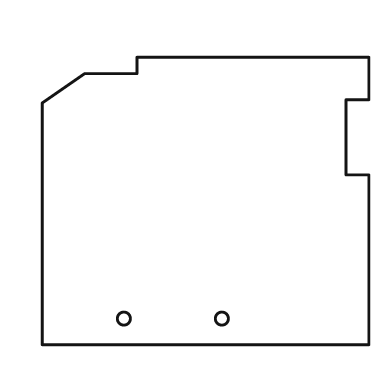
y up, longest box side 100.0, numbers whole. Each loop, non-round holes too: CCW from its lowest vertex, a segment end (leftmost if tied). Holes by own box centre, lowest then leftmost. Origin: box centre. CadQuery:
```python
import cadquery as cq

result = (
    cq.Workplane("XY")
    .moveTo(-50.0, -44.0)
    .lineTo(50.0, -44.0)
    .lineTo(50.0, 8.0)
    .lineTo(43.0, 8.0)
    .lineTo(43.0, 31.0)
    .lineTo(50.0, 31.0)
    .lineTo(50.0, 44.0)
    .lineTo(-21.0, 44.0)
    .lineTo(-21.0, 39.0)
    .lineTo(-37.0, 39.0)
    .lineTo(-50.0, 30.0)
    .close()
    .moveTo(-25.0, -36.0)
    .circle(2.0)
    .moveTo(5.0, -36.0)
    .circle(2.0)
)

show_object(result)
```